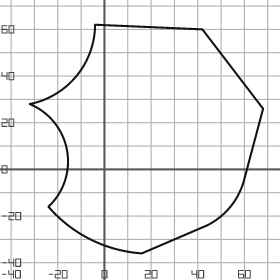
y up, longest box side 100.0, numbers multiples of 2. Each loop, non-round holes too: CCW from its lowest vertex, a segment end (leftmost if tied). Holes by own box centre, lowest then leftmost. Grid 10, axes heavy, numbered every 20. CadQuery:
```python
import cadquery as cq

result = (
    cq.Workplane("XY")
    .moveTo(16.0, -36.0)
    .lineTo(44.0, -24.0)
    .threePointArc((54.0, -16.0), (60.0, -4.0))
    .lineTo(68.0, 26.0)
    .lineTo(42.0, 60.0)
    .lineTo(-4.0, 62.0)
    .threePointArc((-12.0, 40.0), (-32.0, 28.0))
    .threePointArc((-16.0, 8.0), (-24.0, -16.0))
    .threePointArc((-6.0, -30.0), (16.0, -36.0))
    .close()
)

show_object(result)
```